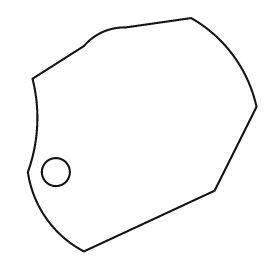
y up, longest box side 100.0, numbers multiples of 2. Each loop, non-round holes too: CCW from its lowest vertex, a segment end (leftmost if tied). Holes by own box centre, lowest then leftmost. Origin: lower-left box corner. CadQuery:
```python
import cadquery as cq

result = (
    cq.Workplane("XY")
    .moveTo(24.0, 0.0)
    .lineTo(80.0, 26.0)
    .lineTo(98.0, 62.0)
    .threePointArc((88.0, 84.0), (70.0, 100.0))
    .lineTo(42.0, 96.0)
    .threePointArc((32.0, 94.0), (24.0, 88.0))
    .lineTo(2.0, 74.0)
    .threePointArc((4.0, 54.0), (0.0, 34.0))
    .threePointArc((8.0, 14.0), (24.0, 0.0))
    .close()
    .moveTo(12.0, 34.0)
    .circle(6.0)
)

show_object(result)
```